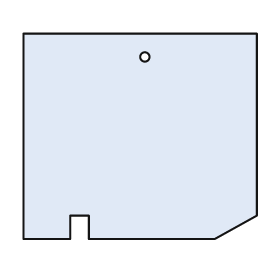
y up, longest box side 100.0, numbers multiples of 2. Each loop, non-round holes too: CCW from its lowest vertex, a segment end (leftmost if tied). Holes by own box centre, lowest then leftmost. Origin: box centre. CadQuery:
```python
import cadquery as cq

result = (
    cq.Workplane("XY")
    .moveTo(-50.0, -44.0)
    .lineTo(-30.0, -44.0)
    .lineTo(-30.0, -34.0)
    .lineTo(-22.0, -34.0)
    .lineTo(-22.0, -44.0)
    .lineTo(32.0, -44.0)
    .lineTo(50.0, -34.0)
    .lineTo(50.0, 44.0)
    .lineTo(-50.0, 44.0)
    .close()
    .moveTo(2.0, 34.0)
    .circle(2.0)
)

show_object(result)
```